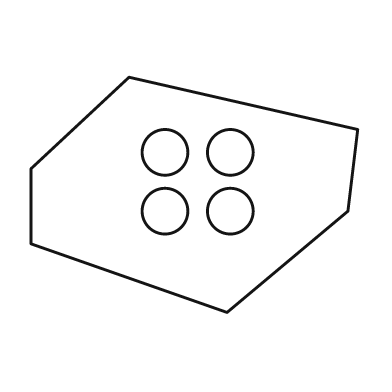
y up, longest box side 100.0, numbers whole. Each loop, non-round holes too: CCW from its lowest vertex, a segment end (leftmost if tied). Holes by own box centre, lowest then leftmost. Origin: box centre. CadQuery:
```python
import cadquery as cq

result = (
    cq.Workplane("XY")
    .moveTo(10.0, -36.0)
    .lineTo(47.0, -5.0)
    .lineTo(50.0, 20.0)
    .lineTo(-20.0, 36.0)
    .lineTo(-50.0, 8.0)
    .lineTo(-50.0, -15.0)
    .close()
    .moveTo(-9.0, -5.0)
    .circle(7.0)
    .moveTo(11.0, -5.0)
    .circle(7.0)
    .moveTo(-9.0, 13.0)
    .circle(7.0)
    .moveTo(11.0, 13.0)
    .circle(7.0)
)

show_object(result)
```